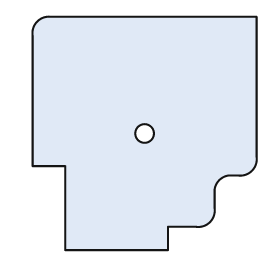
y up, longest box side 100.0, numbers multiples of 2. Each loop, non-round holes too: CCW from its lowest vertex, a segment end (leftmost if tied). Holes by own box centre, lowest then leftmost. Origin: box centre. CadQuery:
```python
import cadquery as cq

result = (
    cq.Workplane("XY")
    .moveTo(-34.0, -50.0)
    .lineTo(10.0, -50.0)
    .lineTo(10.0, -40.0)
    .lineTo(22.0, -40.0)
    .threePointArc((28.0, -38.0), (30.0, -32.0))
    .lineTo(30.0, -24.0)
    .threePointArc((32.0, -20.0), (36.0, -18.0))
    .lineTo(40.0, -18.0)
    .threePointArc((46.0, -16.0), (48.0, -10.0))
    .lineTo(48.0, 50.0)
    .lineTo(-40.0, 50.0)
    .threePointArc((-46.0, 48.0), (-48.0, 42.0))
    .lineTo(-48.0, -14.0)
    .lineTo(-34.0, -14.0)
    .close()
    .moveTo(0.0, 0.0)
    .circle(4.0)
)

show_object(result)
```